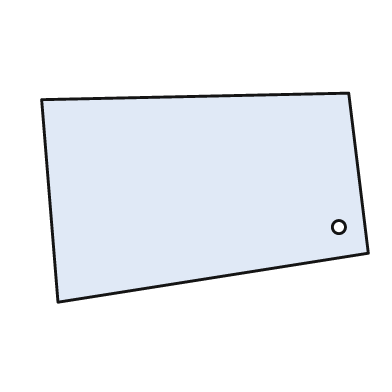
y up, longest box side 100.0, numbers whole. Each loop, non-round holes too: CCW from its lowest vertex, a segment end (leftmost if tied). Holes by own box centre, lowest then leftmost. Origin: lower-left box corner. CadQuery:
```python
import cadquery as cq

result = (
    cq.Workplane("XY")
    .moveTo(5.0, 0.0)
    .lineTo(100.0, 15.0)
    .lineTo(94.0, 64.0)
    .lineTo(0.0, 62.0)
    .close()
    .moveTo(91.0, 23.0)
    .circle(2.0)
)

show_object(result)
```